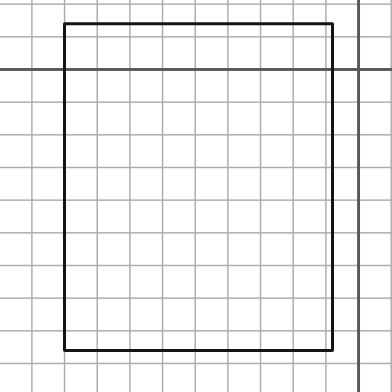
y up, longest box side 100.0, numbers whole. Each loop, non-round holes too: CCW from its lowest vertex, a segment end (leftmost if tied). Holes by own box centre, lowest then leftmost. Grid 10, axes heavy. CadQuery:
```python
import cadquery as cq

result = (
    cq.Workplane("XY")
    .moveTo(-90.0, -86.0)
    .lineTo(-8.0, -86.0)
    .lineTo(-8.0, 14.0)
    .lineTo(-90.0, 14.0)
    .close()
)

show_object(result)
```